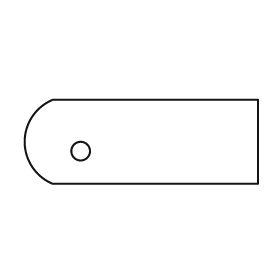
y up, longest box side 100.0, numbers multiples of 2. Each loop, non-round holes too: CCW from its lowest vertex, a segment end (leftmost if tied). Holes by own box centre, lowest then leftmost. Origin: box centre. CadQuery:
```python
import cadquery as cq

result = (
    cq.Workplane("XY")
    .moveTo(-38.0, -18.0)
    .lineTo(50.0, -18.0)
    .lineTo(50.0, 18.0)
    .lineTo(-38.0, 18.0)
    .threePointArc((-50.0, 0.0), (-38.0, -18.0))
    .close()
    .moveTo(-26.0, -4.0)
    .circle(4.0)
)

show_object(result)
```